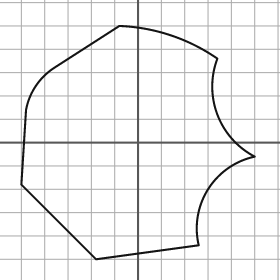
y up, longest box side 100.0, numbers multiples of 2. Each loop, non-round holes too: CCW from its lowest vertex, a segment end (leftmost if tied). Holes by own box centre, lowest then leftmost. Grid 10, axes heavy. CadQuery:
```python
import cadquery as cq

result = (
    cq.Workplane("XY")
    .moveTo(-18.0, -50.0)
    .lineTo(26.0, -44.0)
    .threePointArc((30.0, -20.0), (50.0, -6.0))
    .threePointArc((34.0, 12.0), (34.0, 36.0))
    .threePointArc((14.0, 46.0), (-8.0, 50.0))
    .lineTo(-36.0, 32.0)
    .threePointArc((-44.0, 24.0), (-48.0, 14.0))
    .lineTo(-50.0, -18.0)
    .close()
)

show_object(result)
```